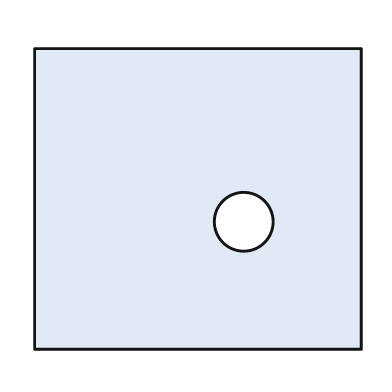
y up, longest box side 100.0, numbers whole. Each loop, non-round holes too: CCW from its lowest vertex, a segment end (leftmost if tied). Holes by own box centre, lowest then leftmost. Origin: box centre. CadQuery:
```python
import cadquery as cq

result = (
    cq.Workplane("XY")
    .moveTo(-50.0, -46.0)
    .lineTo(50.0, -46.0)
    .lineTo(50.0, 46.0)
    .lineTo(-50.0, 46.0)
    .close()
    .moveTo(14.0, -7.0)
    .circle(9.0)
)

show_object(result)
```